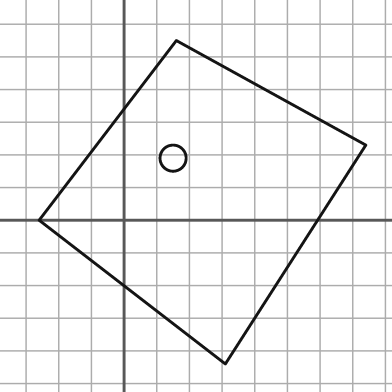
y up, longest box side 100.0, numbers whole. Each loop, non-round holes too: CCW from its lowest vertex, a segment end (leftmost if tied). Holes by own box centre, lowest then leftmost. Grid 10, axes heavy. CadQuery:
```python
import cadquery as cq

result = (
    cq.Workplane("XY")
    .moveTo(31.0, -44.0)
    .lineTo(74.0, 23.0)
    .lineTo(16.0, 55.0)
    .lineTo(-26.0, 0.0)
    .close()
    .moveTo(15.0, 19.0)
    .circle(4.0)
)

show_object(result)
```